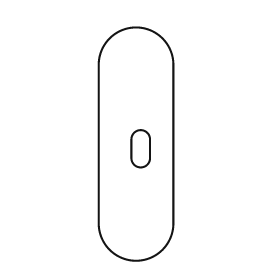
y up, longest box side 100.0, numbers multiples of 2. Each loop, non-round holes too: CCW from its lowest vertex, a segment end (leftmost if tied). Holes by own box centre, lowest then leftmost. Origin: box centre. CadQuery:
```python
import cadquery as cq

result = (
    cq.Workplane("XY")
    .moveTo(-16.0, -34.0)
    .threePointArc((0.0, -50.0), (16.0, -34.0))
    .lineTo(16.0, 34.0)
    .threePointArc((0.0, 50.0), (-16.0, 34.0))
    .close()
    .moveTo(-2.0, -6.0)
    .threePointArc((2.0, -10.0), (6.0, -6.0))
    .lineTo(6.0, 2.0)
    .threePointArc((2.0, 6.0), (-2.0, 2.0))
    .close()
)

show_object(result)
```